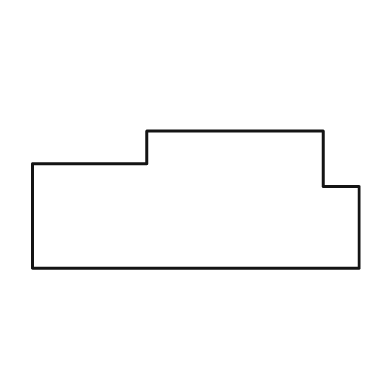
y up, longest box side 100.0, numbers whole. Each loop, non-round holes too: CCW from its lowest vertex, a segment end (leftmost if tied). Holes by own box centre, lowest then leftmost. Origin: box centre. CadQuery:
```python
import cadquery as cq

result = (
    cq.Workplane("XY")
    .moveTo(-50.0, -21.0)
    .lineTo(50.0, -21.0)
    .lineTo(50.0, 4.0)
    .lineTo(39.0, 4.0)
    .lineTo(39.0, 21.0)
    .lineTo(-15.0, 21.0)
    .lineTo(-15.0, 11.0)
    .lineTo(-50.0, 11.0)
    .close()
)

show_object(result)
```